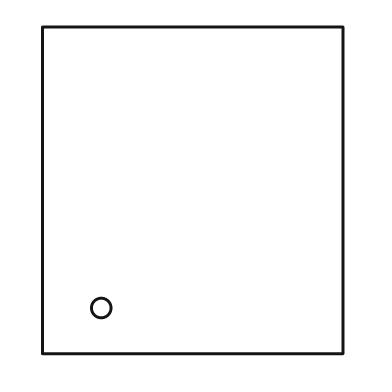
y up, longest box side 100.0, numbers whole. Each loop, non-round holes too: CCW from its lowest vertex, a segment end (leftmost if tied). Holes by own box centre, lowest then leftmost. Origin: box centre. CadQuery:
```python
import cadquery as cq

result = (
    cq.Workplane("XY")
    .moveTo(-46.0, -50.0)
    .lineTo(46.0, -50.0)
    .lineTo(46.0, 50.0)
    .lineTo(-46.0, 50.0)
    .close()
    .moveTo(-28.0, -36.0)
    .circle(3.0)
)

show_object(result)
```